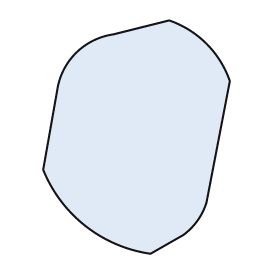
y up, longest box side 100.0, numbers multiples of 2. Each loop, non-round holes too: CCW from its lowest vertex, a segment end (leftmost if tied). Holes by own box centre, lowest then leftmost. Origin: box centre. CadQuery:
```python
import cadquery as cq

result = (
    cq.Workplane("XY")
    .moveTo(6.0, -50.0)
    .lineTo(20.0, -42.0)
    .threePointArc((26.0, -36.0), (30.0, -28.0))
    .lineTo(40.0, 24.0)
    .threePointArc((30.0, 40.0), (14.0, 50.0))
    .lineTo(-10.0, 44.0)
    .threePointArc((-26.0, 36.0), (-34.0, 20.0))
    .lineTo(-40.0, -14.0)
    .threePointArc((-22.0, -38.0), (6.0, -50.0))
    .close()
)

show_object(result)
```